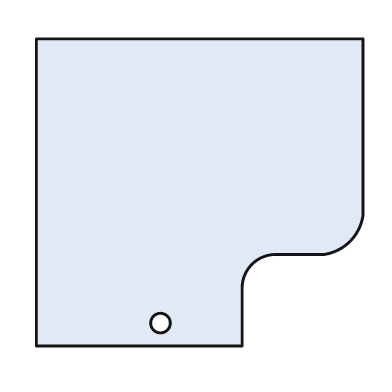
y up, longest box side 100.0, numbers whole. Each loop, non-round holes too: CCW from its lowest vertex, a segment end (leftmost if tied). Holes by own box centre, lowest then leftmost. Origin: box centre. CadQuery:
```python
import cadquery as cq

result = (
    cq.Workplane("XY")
    .moveTo(-50.0, -47.0)
    .lineTo(13.0, -47.0)
    .lineTo(13.0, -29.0)
    .threePointArc((16.0, -22.0), (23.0, -19.0))
    .lineTo(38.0, -19.0)
    .threePointArc((46.0, -15.0), (50.0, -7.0))
    .lineTo(50.0, 47.0)
    .lineTo(-50.0, 47.0)
    .close()
    .moveTo(-12.0, -40.0)
    .circle(3.0)
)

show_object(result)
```